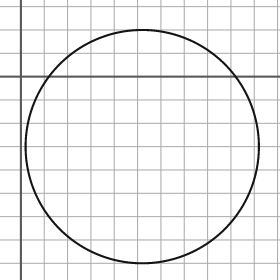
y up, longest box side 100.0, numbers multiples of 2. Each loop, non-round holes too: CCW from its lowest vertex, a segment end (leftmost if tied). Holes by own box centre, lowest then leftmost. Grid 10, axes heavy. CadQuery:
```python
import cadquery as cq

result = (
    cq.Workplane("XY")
    .moveTo(52.0, -30.0)
    .circle(50.0)
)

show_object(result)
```